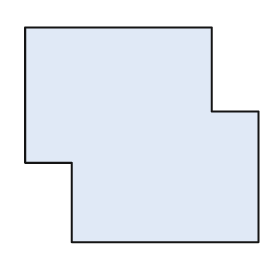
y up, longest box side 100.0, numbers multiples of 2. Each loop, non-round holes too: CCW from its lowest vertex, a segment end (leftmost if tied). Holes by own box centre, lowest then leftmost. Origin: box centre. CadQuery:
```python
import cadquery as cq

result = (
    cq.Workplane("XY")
    .moveTo(-30.0, -46.0)
    .lineTo(50.0, -46.0)
    .lineTo(50.0, 10.0)
    .lineTo(30.0, 10.0)
    .lineTo(30.0, 46.0)
    .lineTo(-50.0, 46.0)
    .lineTo(-50.0, -12.0)
    .lineTo(-30.0, -12.0)
    .close()
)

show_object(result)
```